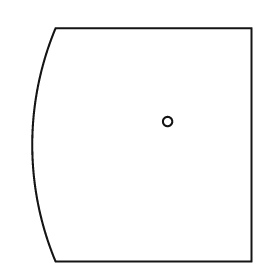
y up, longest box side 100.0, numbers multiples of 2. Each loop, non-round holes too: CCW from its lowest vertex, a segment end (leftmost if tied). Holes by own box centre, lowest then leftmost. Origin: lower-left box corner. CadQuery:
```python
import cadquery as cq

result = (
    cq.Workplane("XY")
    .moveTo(10.0, 0.0)
    .lineTo(94.0, 0.0)
    .lineTo(94.0, 100.0)
    .lineTo(10.0, 100.0)
    .threePointArc((0.0, 50.0), (10.0, 0.0))
    .close()
    .moveTo(58.0, 60.0)
    .circle(2.0)
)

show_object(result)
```